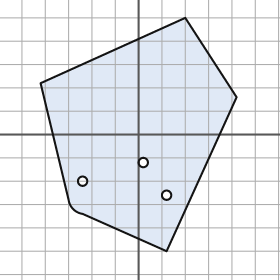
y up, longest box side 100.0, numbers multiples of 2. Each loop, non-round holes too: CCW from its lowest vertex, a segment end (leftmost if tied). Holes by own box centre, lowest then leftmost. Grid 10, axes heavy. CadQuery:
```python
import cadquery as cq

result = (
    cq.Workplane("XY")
    .moveTo(12.0, -50.0)
    .lineTo(42.0, 16.0)
    .lineTo(20.0, 50.0)
    .lineTo(-42.0, 22.0)
    .lineTo(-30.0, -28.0)
    .threePointArc((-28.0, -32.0), (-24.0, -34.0))
    .close()
    .moveTo(12.0, -26.0)
    .circle(2.0)
    .moveTo(-24.0, -20.0)
    .circle(2.0)
    .moveTo(2.0, -12.0)
    .circle(2.0)
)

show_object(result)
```